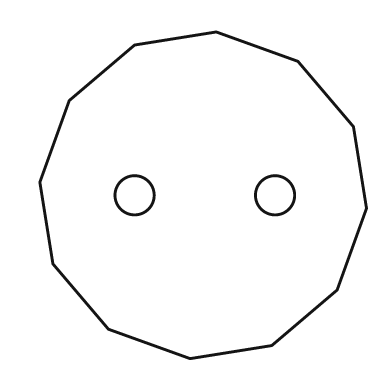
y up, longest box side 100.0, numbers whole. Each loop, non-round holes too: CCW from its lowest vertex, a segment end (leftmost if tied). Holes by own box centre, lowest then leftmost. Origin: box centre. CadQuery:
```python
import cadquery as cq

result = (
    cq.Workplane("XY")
    .moveTo(-4.0, -50.0)
    .lineTo(21.0, -46.0)
    .lineTo(41.0, -29.0)
    .lineTo(50.0, -4.0)
    .lineTo(46.0, 21.0)
    .lineTo(29.0, 41.0)
    .lineTo(4.0, 50.0)
    .lineTo(-21.0, 46.0)
    .lineTo(-41.0, 29.0)
    .lineTo(-50.0, 4.0)
    .lineTo(-46.0, -21.0)
    .lineTo(-29.0, -41.0)
    .close()
    .moveTo(-21.0, 0.0)
    .circle(6.0)
    .moveTo(22.0, 0.0)
    .circle(6.0)
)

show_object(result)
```